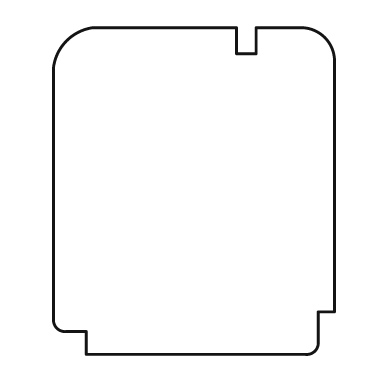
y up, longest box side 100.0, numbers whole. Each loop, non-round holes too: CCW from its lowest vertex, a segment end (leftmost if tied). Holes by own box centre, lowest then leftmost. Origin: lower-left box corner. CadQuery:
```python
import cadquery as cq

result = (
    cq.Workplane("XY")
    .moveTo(10.0, 0.0)
    .lineTo(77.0, 0.0)
    .threePointArc((80.0, 1.0), (81.0, 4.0))
    .lineTo(81.0, 13.0)
    .lineTo(86.0, 13.0)
    .lineTo(86.0, 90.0)
    .threePointArc((83.0, 97.0), (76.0, 100.0))
    .lineTo(62.0, 100.0)
    .lineTo(62.0, 92.0)
    .lineTo(56.0, 92.0)
    .lineTo(56.0, 100.0)
    .lineTo(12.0, 100.0)
    .threePointArc((4.0, 96.0), (0.0, 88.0))
    .lineTo(0.0, 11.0)
    .threePointArc((1.0, 8.0), (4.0, 7.0))
    .lineTo(10.0, 7.0)
    .close()
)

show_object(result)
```